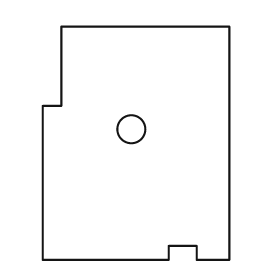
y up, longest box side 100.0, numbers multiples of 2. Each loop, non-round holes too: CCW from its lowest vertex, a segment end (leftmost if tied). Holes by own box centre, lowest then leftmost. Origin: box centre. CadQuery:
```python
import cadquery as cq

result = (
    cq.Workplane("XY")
    .moveTo(-40.0, -50.0)
    .lineTo(14.0, -50.0)
    .lineTo(14.0, -44.0)
    .lineTo(26.0, -44.0)
    .lineTo(26.0, -50.0)
    .lineTo(40.0, -50.0)
    .lineTo(40.0, 50.0)
    .lineTo(-32.0, 50.0)
    .lineTo(-32.0, 16.0)
    .lineTo(-40.0, 16.0)
    .close()
    .moveTo(-2.0, 6.0)
    .circle(6.0)
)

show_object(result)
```